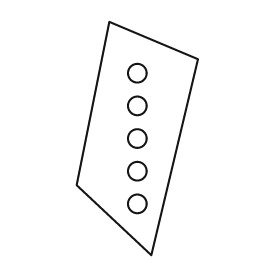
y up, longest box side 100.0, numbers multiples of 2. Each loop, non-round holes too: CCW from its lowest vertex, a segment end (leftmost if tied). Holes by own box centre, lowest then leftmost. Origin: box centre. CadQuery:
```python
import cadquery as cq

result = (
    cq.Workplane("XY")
    .moveTo(6.0, -50.0)
    .lineTo(26.0, 34.0)
    .lineTo(-12.0, 50.0)
    .lineTo(-26.0, -20.0)
    .close()
    .moveTo(0.0, -28.0)
    .circle(4.0)
    .moveTo(0.0, -14.0)
    .circle(4.0)
    .moveTo(0.0, 0.0)
    .circle(4.0)
    .moveTo(0.0, 14.0)
    .circle(4.0)
    .moveTo(0.0, 28.0)
    .circle(4.0)
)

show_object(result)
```